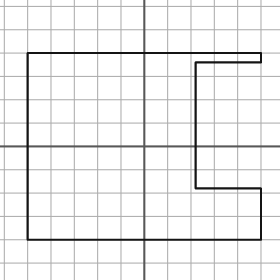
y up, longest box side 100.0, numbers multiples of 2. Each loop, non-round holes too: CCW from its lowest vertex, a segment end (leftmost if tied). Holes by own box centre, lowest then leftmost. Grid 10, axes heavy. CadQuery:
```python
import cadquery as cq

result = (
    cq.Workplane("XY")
    .moveTo(-50.0, -40.0)
    .lineTo(50.0, -40.0)
    .lineTo(50.0, -18.0)
    .lineTo(22.0, -18.0)
    .lineTo(22.0, 36.0)
    .lineTo(50.0, 36.0)
    .lineTo(50.0, 40.0)
    .lineTo(-50.0, 40.0)
    .close()
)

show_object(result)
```